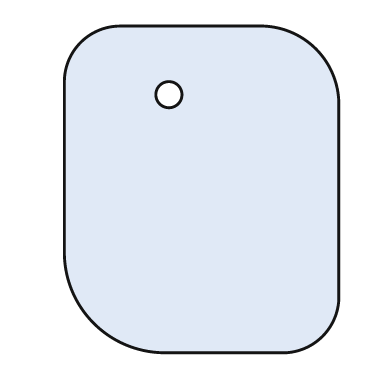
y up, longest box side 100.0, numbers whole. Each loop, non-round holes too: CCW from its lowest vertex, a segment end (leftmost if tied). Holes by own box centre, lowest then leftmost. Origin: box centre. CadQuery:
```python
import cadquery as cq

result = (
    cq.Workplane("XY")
    .moveTo(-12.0, -50.0)
    .lineTo(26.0, -50.0)
    .threePointArc((37.0, -45.0), (42.0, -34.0))
    .lineTo(42.0, 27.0)
    .threePointArc((35.0, 43.0), (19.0, 50.0))
    .lineTo(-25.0, 50.0)
    .threePointArc((-37.0, 45.0), (-42.0, 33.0))
    .lineTo(-42.0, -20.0)
    .threePointArc((-33.0, -41.0), (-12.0, -50.0))
    .close()
    .moveTo(-10.0, 29.0)
    .circle(4.0)
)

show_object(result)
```